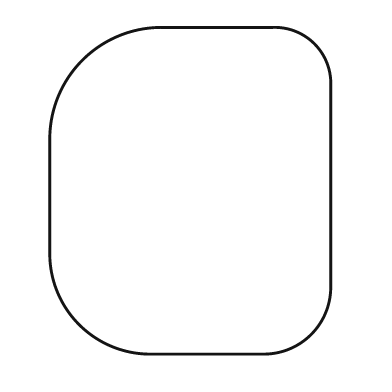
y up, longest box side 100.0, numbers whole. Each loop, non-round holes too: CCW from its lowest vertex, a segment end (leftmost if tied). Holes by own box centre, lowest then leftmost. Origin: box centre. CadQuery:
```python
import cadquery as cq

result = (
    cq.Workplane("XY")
    .moveTo(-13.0, -50.0)
    .lineTo(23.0, -50.0)
    .threePointArc((37.0, -44.0), (43.0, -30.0))
    .lineTo(43.0, 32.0)
    .threePointArc((38.0, 45.0), (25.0, 50.0))
    .lineTo(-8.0, 50.0)
    .threePointArc((-33.0, 40.0), (-43.0, 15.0))
    .lineTo(-43.0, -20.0)
    .threePointArc((-34.0, -41.0), (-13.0, -50.0))
    .close()
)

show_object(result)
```